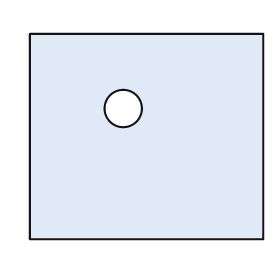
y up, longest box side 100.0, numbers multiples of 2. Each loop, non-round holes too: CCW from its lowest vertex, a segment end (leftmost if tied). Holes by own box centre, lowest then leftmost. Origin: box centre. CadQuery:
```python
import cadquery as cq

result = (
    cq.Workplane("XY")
    .moveTo(-50.0, -44.0)
    .lineTo(50.0, -44.0)
    .lineTo(50.0, 44.0)
    .lineTo(-50.0, 44.0)
    .close()
    .moveTo(-10.0, 12.0)
    .circle(8.0)
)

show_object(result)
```